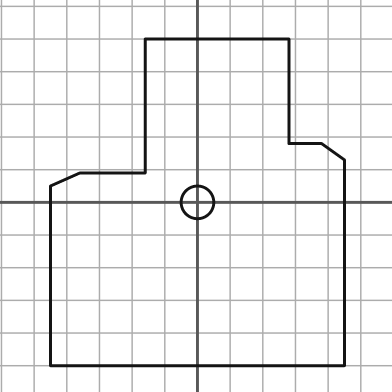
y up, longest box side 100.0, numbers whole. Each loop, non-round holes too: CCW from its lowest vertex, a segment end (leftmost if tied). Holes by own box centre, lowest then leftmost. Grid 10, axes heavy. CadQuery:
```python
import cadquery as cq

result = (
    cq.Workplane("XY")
    .moveTo(-45.0, -50.0)
    .lineTo(45.0, -50.0)
    .lineTo(45.0, 13.0)
    .lineTo(38.0, 18.0)
    .lineTo(28.0, 18.0)
    .lineTo(28.0, 50.0)
    .lineTo(-16.0, 50.0)
    .lineTo(-16.0, 9.0)
    .lineTo(-36.0, 9.0)
    .lineTo(-45.0, 5.0)
    .close()
    .moveTo(0.0, 0.0)
    .circle(5.0)
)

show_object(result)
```